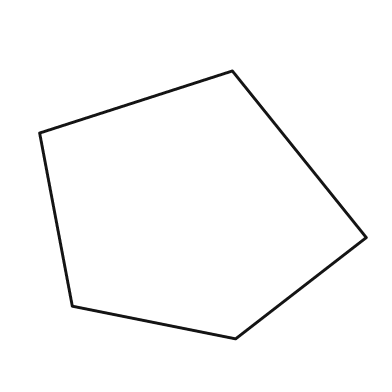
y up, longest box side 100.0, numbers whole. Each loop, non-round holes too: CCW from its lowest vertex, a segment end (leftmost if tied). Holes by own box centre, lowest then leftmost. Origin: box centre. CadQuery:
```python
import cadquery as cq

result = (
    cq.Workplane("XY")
    .moveTo(10.0, -41.0)
    .lineTo(50.0, -10.0)
    .lineTo(9.0, 41.0)
    .lineTo(-50.0, 22.0)
    .lineTo(-40.0, -31.0)
    .close()
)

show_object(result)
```